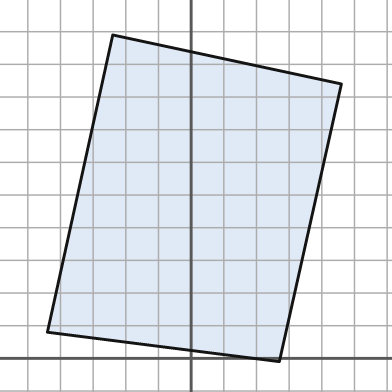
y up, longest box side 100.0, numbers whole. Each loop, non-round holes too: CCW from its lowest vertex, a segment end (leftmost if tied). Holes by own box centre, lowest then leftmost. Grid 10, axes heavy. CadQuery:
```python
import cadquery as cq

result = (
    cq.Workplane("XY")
    .moveTo(27.0, -1.0)
    .lineTo(46.0, 84.0)
    .lineTo(-24.0, 99.0)
    .lineTo(-44.0, 8.0)
    .close()
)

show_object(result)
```